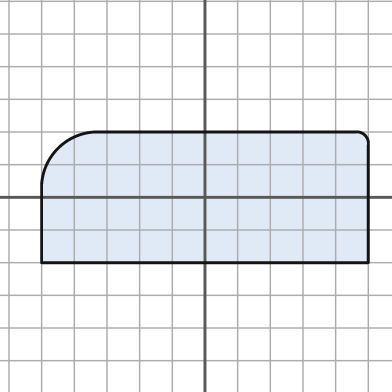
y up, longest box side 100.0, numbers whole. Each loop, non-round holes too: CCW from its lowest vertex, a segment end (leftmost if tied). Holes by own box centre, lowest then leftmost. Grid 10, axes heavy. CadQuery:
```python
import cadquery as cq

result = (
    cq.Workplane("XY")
    .moveTo(-50.0, -20.0)
    .lineTo(50.0, -20.0)
    .lineTo(50.0, 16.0)
    .threePointArc((49.0, 19.0), (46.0, 20.0))
    .lineTo(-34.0, 20.0)
    .threePointArc((-45.0, 15.0), (-50.0, 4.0))
    .close()
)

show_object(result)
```